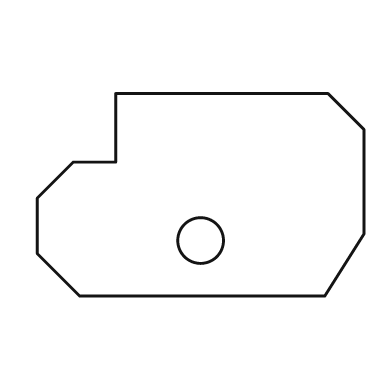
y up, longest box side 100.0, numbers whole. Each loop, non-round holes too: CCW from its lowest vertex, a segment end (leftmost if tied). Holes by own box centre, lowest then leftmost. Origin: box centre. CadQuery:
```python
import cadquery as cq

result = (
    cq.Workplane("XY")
    .moveTo(-37.0, -31.0)
    .lineTo(38.0, -31.0)
    .lineTo(50.0, -12.0)
    .lineTo(50.0, 20.0)
    .lineTo(39.0, 31.0)
    .lineTo(-26.0, 31.0)
    .lineTo(-26.0, 10.0)
    .lineTo(-39.0, 10.0)
    .lineTo(-50.0, -1.0)
    .lineTo(-50.0, -18.0)
    .close()
    .moveTo(0.0, -14.0)
    .circle(7.0)
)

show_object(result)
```